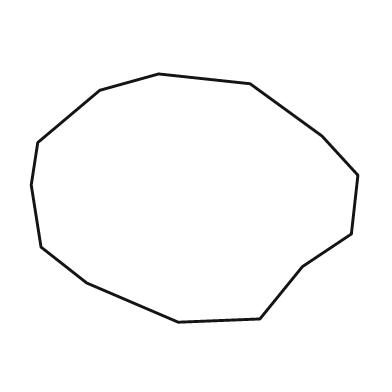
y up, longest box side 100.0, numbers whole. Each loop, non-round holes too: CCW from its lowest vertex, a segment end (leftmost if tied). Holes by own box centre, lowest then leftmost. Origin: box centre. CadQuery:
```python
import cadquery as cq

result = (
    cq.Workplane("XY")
    .moveTo(-5.0, -38.0)
    .lineTo(20.0, -37.0)
    .lineTo(33.0, -21.0)
    .lineTo(48.0, -11.0)
    .lineTo(50.0, 7.0)
    .lineTo(39.0, 19.0)
    .lineTo(17.0, 35.0)
    .lineTo(-11.0, 38.0)
    .lineTo(-29.0, 33.0)
    .lineTo(-48.0, 17.0)
    .lineTo(-50.0, 4.0)
    .lineTo(-47.0, -15.0)
    .lineTo(-33.0, -26.0)
    .close()
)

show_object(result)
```